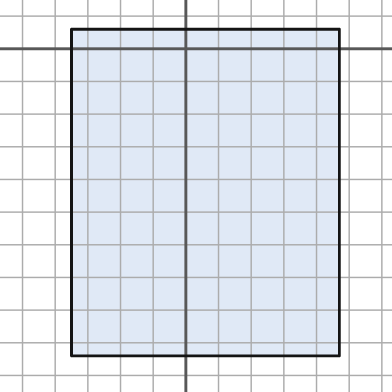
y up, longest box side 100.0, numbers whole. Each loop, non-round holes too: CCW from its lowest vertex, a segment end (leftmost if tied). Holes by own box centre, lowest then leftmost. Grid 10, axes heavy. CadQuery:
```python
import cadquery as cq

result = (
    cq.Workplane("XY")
    .moveTo(-35.0, -94.0)
    .lineTo(47.0, -94.0)
    .lineTo(47.0, 6.0)
    .lineTo(-35.0, 6.0)
    .close()
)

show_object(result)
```